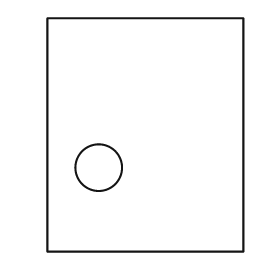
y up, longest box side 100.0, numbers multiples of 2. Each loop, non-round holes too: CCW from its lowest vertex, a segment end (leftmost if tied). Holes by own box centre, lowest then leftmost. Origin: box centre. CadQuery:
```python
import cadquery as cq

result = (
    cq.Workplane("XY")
    .moveTo(-42.0, -50.0)
    .lineTo(42.0, -50.0)
    .lineTo(42.0, 50.0)
    .lineTo(-42.0, 50.0)
    .close()
    .moveTo(-20.0, -14.0)
    .circle(10.0)
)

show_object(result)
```